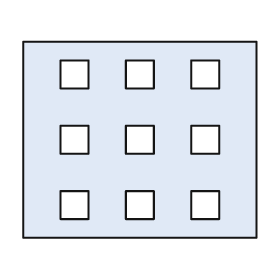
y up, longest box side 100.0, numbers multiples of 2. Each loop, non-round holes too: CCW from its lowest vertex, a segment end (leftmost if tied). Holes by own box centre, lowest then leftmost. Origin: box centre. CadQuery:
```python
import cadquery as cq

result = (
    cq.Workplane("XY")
    .moveTo(-50.0, -42.0)
    .lineTo(50.0, -42.0)
    .lineTo(50.0, 42.0)
    .lineTo(-50.0, 42.0)
    .close()
    .moveTo(-34.0, -34.0)
    .lineTo(-22.0, -34.0)
    .lineTo(-22.0, -22.0)
    .lineTo(-34.0, -22.0)
    .close()
    .moveTo(-6.0, -34.0)
    .lineTo(6.0, -34.0)
    .lineTo(6.0, -22.0)
    .lineTo(-6.0, -22.0)
    .close()
    .moveTo(22.0, -34.0)
    .lineTo(34.0, -34.0)
    .lineTo(34.0, -22.0)
    .lineTo(22.0, -22.0)
    .close()
    .moveTo(-34.0, -6.0)
    .lineTo(-22.0, -6.0)
    .lineTo(-22.0, 6.0)
    .lineTo(-34.0, 6.0)
    .close()
    .moveTo(-6.0, -6.0)
    .lineTo(6.0, -6.0)
    .lineTo(6.0, 6.0)
    .lineTo(-6.0, 6.0)
    .close()
    .moveTo(22.0, -6.0)
    .lineTo(34.0, -6.0)
    .lineTo(34.0, 6.0)
    .lineTo(22.0, 6.0)
    .close()
    .moveTo(-34.0, 22.0)
    .lineTo(-22.0, 22.0)
    .lineTo(-22.0, 34.0)
    .lineTo(-34.0, 34.0)
    .close()
    .moveTo(-6.0, 22.0)
    .lineTo(6.0, 22.0)
    .lineTo(6.0, 34.0)
    .lineTo(-6.0, 34.0)
    .close()
    .moveTo(22.0, 22.0)
    .lineTo(34.0, 22.0)
    .lineTo(34.0, 34.0)
    .lineTo(22.0, 34.0)
    .close()
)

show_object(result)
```